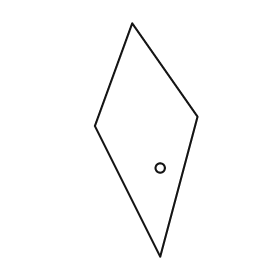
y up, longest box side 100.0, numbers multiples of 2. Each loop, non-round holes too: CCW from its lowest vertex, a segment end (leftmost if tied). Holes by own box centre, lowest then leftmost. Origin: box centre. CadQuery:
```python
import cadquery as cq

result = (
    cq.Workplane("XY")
    .moveTo(6.0, -50.0)
    .lineTo(22.0, 10.0)
    .lineTo(-6.0, 50.0)
    .lineTo(-22.0, 6.0)
    .close()
    .moveTo(6.0, -12.0)
    .circle(2.0)
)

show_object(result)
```